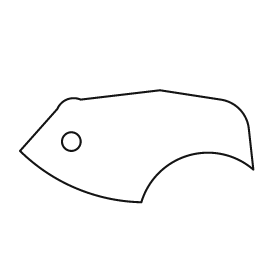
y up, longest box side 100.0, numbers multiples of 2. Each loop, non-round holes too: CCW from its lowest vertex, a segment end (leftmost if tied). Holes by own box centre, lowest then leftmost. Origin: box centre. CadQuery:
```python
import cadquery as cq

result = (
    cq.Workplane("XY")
    .moveTo(2.0, -24.0)
    .threePointArc((22.0, -4.0), (50.0, -10.0))
    .lineTo(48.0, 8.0)
    .threePointArc((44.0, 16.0), (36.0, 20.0))
    .lineTo(10.0, 24.0)
    .lineTo(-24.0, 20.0)
    .threePointArc((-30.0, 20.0), (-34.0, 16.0))
    .lineTo(-50.0, -2.0)
    .threePointArc((-26.0, -18.0), (2.0, -24.0))
    .close()
    .moveTo(-28.0, 2.0)
    .circle(4.0)
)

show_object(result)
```